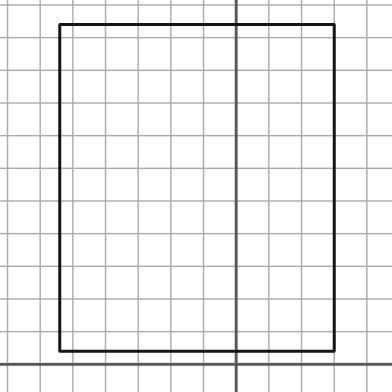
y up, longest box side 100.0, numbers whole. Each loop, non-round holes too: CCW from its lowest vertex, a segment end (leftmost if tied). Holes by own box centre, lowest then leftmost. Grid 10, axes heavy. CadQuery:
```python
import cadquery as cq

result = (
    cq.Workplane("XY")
    .moveTo(-54.0, 4.0)
    .lineTo(30.0, 4.0)
    .lineTo(30.0, 104.0)
    .lineTo(-54.0, 104.0)
    .close()
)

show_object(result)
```